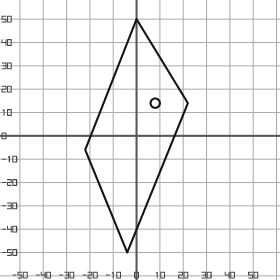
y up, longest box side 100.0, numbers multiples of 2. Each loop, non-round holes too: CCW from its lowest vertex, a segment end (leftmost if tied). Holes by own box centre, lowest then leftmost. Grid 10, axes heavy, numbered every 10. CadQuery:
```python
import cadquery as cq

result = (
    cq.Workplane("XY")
    .moveTo(-4.0, -50.0)
    .lineTo(22.0, 14.0)
    .lineTo(0.0, 50.0)
    .lineTo(-22.0, -6.0)
    .close()
    .moveTo(8.0, 14.0)
    .circle(2.0)
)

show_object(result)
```